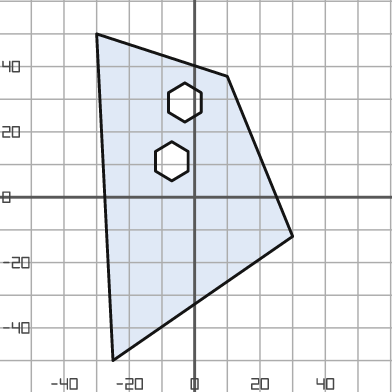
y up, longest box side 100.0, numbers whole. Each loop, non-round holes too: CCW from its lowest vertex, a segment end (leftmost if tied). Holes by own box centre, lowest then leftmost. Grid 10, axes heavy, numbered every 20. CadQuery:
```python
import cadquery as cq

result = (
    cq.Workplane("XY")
    .moveTo(-25.0, -50.0)
    .lineTo(30.0, -12.0)
    .lineTo(10.0, 37.0)
    .lineTo(-30.0, 50.0)
    .close()
    .moveTo(-7.0, 5.0)
    .lineTo(-2.0, 8.0)
    .lineTo(-2.0, 14.0)
    .lineTo(-7.0, 17.0)
    .lineTo(-12.0, 14.0)
    .lineTo(-12.0, 8.0)
    .close()
    .moveTo(-3.0, 23.0)
    .lineTo(2.0, 26.0)
    .lineTo(2.0, 32.0)
    .lineTo(-3.0, 35.0)
    .lineTo(-8.0, 32.0)
    .lineTo(-8.0, 26.0)
    .close()
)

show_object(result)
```